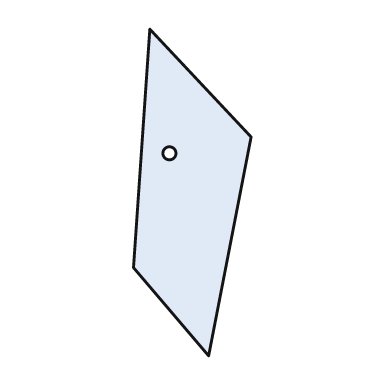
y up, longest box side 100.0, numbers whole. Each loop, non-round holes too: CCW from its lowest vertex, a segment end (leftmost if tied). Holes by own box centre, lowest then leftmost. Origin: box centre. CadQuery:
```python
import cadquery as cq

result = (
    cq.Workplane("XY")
    .moveTo(5.0, -50.0)
    .lineTo(18.0, 17.0)
    .lineTo(-13.0, 50.0)
    .lineTo(-18.0, -23.0)
    .close()
    .moveTo(-7.0, 12.0)
    .circle(2.0)
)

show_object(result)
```